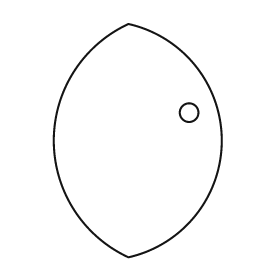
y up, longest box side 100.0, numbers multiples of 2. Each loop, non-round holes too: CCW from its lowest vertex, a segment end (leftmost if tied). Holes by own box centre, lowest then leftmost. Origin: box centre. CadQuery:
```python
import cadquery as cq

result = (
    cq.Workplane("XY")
    .moveTo(-4.0, -50.0)
    .threePointArc((36.0, 0.0), (-4.0, 50.0))
    .threePointArc((-36.0, 0.0), (-4.0, -50.0))
    .close()
    .moveTo(22.0, 12.0)
    .circle(4.0)
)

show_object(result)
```